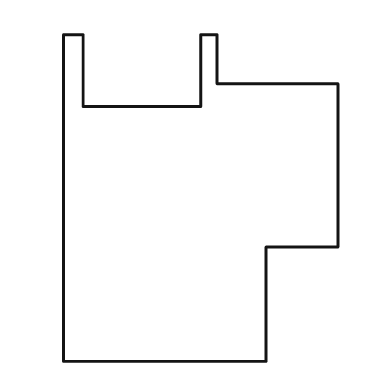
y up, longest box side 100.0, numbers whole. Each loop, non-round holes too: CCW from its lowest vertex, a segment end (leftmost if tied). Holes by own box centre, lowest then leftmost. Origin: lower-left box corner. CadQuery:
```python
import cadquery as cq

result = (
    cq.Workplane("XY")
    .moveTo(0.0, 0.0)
    .lineTo(62.0, 0.0)
    .lineTo(62.0, 35.0)
    .lineTo(84.0, 35.0)
    .lineTo(84.0, 85.0)
    .lineTo(47.0, 85.0)
    .lineTo(47.0, 100.0)
    .lineTo(42.0, 100.0)
    .lineTo(42.0, 78.0)
    .lineTo(6.0, 78.0)
    .lineTo(6.0, 100.0)
    .lineTo(0.0, 100.0)
    .close()
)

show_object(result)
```